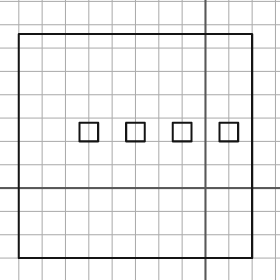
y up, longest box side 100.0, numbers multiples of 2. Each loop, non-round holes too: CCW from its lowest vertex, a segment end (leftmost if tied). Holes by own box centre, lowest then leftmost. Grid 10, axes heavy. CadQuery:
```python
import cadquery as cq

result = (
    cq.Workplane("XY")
    .moveTo(-80.0, -30.0)
    .lineTo(20.0, -30.0)
    .lineTo(20.0, 66.0)
    .lineTo(-80.0, 66.0)
    .close()
    .moveTo(-54.0, 20.0)
    .lineTo(-46.0, 20.0)
    .lineTo(-46.0, 28.0)
    .lineTo(-54.0, 28.0)
    .close()
    .moveTo(-34.0, 20.0)
    .lineTo(-26.0, 20.0)
    .lineTo(-26.0, 28.0)
    .lineTo(-34.0, 28.0)
    .close()
    .moveTo(-14.0, 20.0)
    .lineTo(-6.0, 20.0)
    .lineTo(-6.0, 28.0)
    .lineTo(-14.0, 28.0)
    .close()
    .moveTo(6.0, 20.0)
    .lineTo(14.0, 20.0)
    .lineTo(14.0, 28.0)
    .lineTo(6.0, 28.0)
    .close()
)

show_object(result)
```